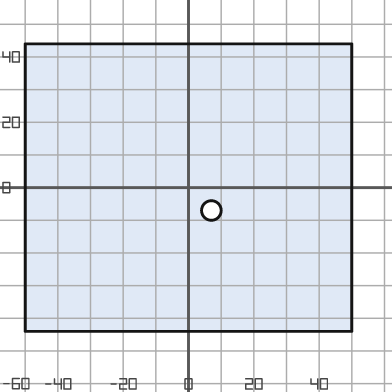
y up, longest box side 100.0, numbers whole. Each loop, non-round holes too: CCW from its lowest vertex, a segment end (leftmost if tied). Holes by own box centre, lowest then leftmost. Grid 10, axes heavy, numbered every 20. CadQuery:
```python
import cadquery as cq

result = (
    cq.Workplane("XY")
    .moveTo(-50.0, -44.0)
    .lineTo(50.0, -44.0)
    .lineTo(50.0, 44.0)
    .lineTo(-50.0, 44.0)
    .close()
    .moveTo(7.0, -7.0)
    .circle(3.0)
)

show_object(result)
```